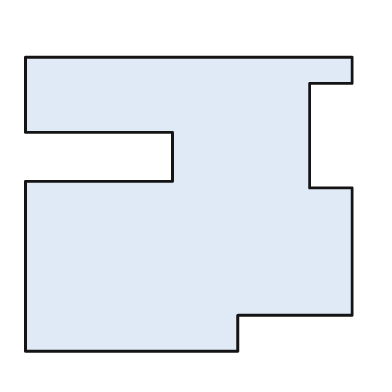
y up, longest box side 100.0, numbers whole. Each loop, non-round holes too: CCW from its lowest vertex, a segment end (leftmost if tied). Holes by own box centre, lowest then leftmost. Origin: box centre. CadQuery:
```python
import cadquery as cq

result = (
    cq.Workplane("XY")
    .moveTo(-50.0, -45.0)
    .lineTo(15.0, -45.0)
    .lineTo(15.0, -34.0)
    .lineTo(50.0, -34.0)
    .lineTo(50.0, 5.0)
    .lineTo(37.0, 5.0)
    .lineTo(37.0, 37.0)
    .lineTo(50.0, 37.0)
    .lineTo(50.0, 45.0)
    .lineTo(-50.0, 45.0)
    .lineTo(-50.0, 22.0)
    .lineTo(-5.0, 22.0)
    .lineTo(-5.0, 7.0)
    .lineTo(-50.0, 7.0)
    .close()
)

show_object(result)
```